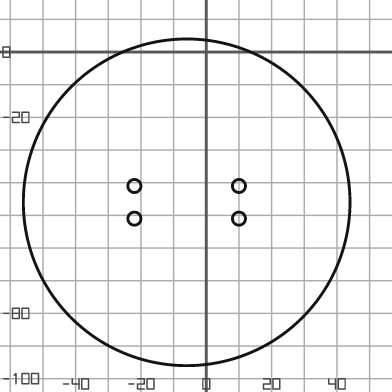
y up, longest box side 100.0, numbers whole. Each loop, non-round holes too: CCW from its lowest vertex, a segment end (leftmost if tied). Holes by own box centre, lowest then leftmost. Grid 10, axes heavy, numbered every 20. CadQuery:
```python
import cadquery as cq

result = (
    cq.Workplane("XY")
    .moveTo(-6.0, -46.0)
    .circle(50.0)
    .moveTo(-22.0, -51.0)
    .circle(2.0)
    .moveTo(10.0, -51.0)
    .circle(2.0)
    .moveTo(-22.0, -41.0)
    .circle(2.0)
    .moveTo(10.0, -41.0)
    .circle(2.0)
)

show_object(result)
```